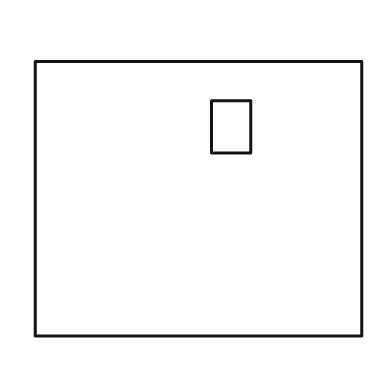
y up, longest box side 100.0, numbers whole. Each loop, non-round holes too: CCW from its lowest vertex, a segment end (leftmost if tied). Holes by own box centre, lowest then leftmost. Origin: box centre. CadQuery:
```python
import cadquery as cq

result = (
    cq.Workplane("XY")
    .moveTo(-50.0, -42.0)
    .lineTo(50.0, -42.0)
    .lineTo(50.0, 42.0)
    .lineTo(-50.0, 42.0)
    .close()
    .moveTo(4.0, 14.0)
    .lineTo(16.0, 14.0)
    .lineTo(16.0, 30.0)
    .lineTo(4.0, 30.0)
    .close()
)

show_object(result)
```